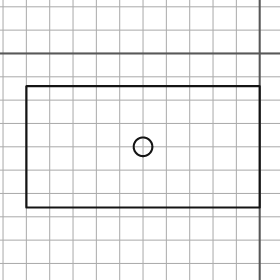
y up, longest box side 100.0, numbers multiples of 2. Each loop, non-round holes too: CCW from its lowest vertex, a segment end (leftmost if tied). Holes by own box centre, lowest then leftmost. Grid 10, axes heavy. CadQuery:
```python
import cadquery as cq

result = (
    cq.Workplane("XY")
    .moveTo(-100.0, -66.0)
    .lineTo(0.0, -66.0)
    .lineTo(0.0, -14.0)
    .lineTo(-100.0, -14.0)
    .close()
    .moveTo(-50.0, -40.0)
    .circle(4.0)
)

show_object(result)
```